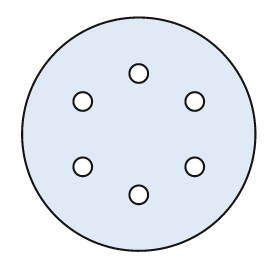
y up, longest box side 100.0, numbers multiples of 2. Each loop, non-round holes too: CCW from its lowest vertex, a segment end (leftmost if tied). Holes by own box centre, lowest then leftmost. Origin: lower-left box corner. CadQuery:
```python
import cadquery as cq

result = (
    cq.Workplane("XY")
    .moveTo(50.0, 50.0)
    .circle(50.0)
    .moveTo(50.0, 24.0)
    .circle(4.0)
    .moveTo(26.0, 36.0)
    .circle(4.0)
    .moveTo(74.0, 36.0)
    .circle(4.0)
    .moveTo(26.0, 64.0)
    .circle(4.0)
    .moveTo(74.0, 64.0)
    .circle(4.0)
    .moveTo(50.0, 76.0)
    .circle(4.0)
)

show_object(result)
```